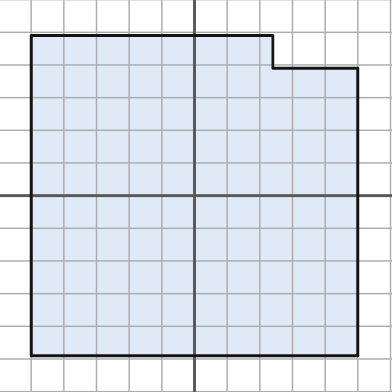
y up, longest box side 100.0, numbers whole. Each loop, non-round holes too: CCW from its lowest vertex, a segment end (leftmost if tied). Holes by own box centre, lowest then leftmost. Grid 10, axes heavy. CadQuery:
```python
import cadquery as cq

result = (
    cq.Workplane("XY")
    .moveTo(-50.0, -49.0)
    .lineTo(50.0, -49.0)
    .lineTo(50.0, 39.0)
    .lineTo(24.0, 39.0)
    .lineTo(24.0, 49.0)
    .lineTo(-50.0, 49.0)
    .close()
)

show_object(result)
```